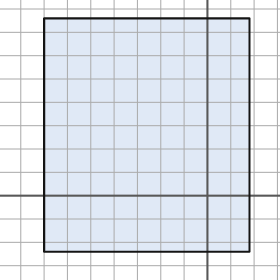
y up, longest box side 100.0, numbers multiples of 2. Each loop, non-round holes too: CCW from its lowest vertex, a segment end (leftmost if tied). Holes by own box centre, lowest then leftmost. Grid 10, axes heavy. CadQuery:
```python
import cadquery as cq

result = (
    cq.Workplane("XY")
    .moveTo(-70.0, -24.0)
    .lineTo(18.0, -24.0)
    .lineTo(18.0, 76.0)
    .lineTo(-70.0, 76.0)
    .close()
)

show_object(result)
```